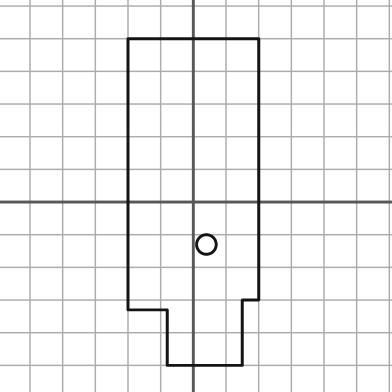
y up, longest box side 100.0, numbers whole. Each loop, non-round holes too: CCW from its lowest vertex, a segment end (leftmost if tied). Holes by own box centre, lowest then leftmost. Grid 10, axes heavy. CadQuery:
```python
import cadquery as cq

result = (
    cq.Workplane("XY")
    .moveTo(-8.0, -50.0)
    .lineTo(15.0, -50.0)
    .lineTo(15.0, -30.0)
    .lineTo(20.0, -30.0)
    .lineTo(20.0, 50.0)
    .lineTo(-20.0, 50.0)
    .lineTo(-20.0, -33.0)
    .lineTo(-8.0, -33.0)
    .close()
    .moveTo(4.0, -13.0)
    .circle(3.0)
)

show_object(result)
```